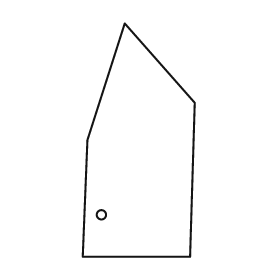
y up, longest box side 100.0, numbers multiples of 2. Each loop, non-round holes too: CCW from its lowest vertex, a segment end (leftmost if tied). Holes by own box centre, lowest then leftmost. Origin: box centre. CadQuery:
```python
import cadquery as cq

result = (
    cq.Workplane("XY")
    .moveTo(-24.0, -50.0)
    .lineTo(22.0, -50.0)
    .lineTo(24.0, 16.0)
    .lineTo(-6.0, 50.0)
    .lineTo(-22.0, 0.0)
    .close()
    .moveTo(-16.0, -32.0)
    .circle(2.0)
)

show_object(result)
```